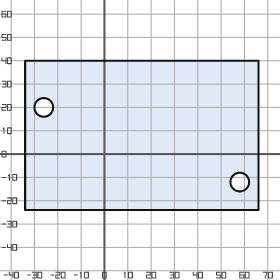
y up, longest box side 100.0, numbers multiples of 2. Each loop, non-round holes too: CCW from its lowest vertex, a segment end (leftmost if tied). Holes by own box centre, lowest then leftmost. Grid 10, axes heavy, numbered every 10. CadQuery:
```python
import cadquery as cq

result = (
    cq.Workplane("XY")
    .moveTo(-34.0, -24.0)
    .lineTo(66.0, -24.0)
    .lineTo(66.0, 40.0)
    .lineTo(-34.0, 40.0)
    .close()
    .moveTo(58.0, -12.0)
    .circle(4.0)
    .moveTo(-26.0, 20.0)
    .circle(4.0)
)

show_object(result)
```